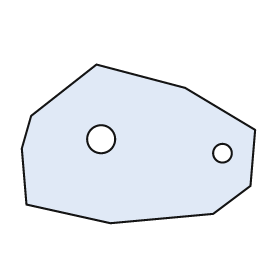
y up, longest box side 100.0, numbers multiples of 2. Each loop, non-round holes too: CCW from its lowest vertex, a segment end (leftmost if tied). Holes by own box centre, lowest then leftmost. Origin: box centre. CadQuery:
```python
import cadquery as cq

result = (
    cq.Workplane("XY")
    .moveTo(-12.0, -34.0)
    .lineTo(32.0, -30.0)
    .lineTo(48.0, -18.0)
    .lineTo(50.0, 6.0)
    .lineTo(20.0, 24.0)
    .lineTo(-18.0, 34.0)
    .lineTo(-46.0, 12.0)
    .lineTo(-50.0, -2.0)
    .lineTo(-48.0, -26.0)
    .close()
    .moveTo(36.0, -4.0)
    .circle(4.0)
    .moveTo(-16.0, 2.0)
    .circle(6.0)
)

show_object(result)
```